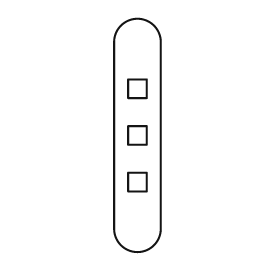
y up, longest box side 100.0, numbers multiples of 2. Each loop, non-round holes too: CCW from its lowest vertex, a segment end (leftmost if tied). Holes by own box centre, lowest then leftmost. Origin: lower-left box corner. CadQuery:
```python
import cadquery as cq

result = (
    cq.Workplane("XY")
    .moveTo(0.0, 10.0)
    .threePointArc((10.0, 0.0), (20.0, 10.0))
    .lineTo(20.0, 90.0)
    .threePointArc((10.0, 100.0), (0.0, 90.0))
    .close()
    .moveTo(6.0, 26.0)
    .lineTo(14.0, 26.0)
    .lineTo(14.0, 34.0)
    .lineTo(6.0, 34.0)
    .close()
    .moveTo(6.0, 46.0)
    .lineTo(14.0, 46.0)
    .lineTo(14.0, 54.0)
    .lineTo(6.0, 54.0)
    .close()
    .moveTo(6.0, 66.0)
    .lineTo(14.0, 66.0)
    .lineTo(14.0, 74.0)
    .lineTo(6.0, 74.0)
    .close()
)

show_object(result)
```